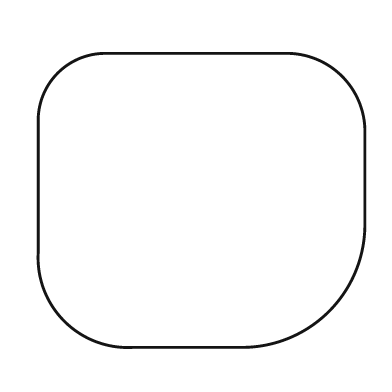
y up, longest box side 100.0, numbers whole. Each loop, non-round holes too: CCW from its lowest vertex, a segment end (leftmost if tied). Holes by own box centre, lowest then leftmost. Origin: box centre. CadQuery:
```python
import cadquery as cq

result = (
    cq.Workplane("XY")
    .moveTo(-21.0, -45.0)
    .lineTo(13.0, -45.0)
    .threePointArc((39.0, -34.0), (50.0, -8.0))
    .lineTo(50.0, 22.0)
    .threePointArc((43.0, 38.0), (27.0, 45.0))
    .lineTo(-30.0, 45.0)
    .threePointArc((-44.0, 39.0), (-50.0, 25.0))
    .lineTo(-50.0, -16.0)
    .threePointArc((-42.0, -37.0), (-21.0, -45.0))
    .close()
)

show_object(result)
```